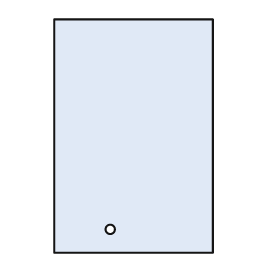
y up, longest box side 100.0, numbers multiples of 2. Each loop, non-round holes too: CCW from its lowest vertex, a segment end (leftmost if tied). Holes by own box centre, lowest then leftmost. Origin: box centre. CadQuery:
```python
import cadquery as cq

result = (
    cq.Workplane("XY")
    .moveTo(-34.0, -50.0)
    .lineTo(34.0, -50.0)
    .lineTo(34.0, 50.0)
    .lineTo(-34.0, 50.0)
    .close()
    .moveTo(-10.0, -40.0)
    .circle(2.0)
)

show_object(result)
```